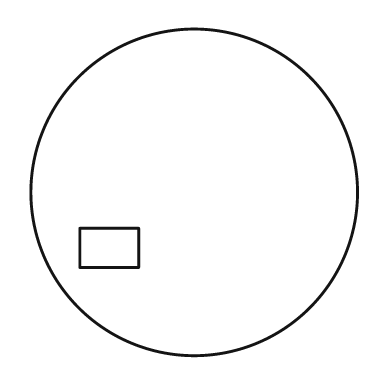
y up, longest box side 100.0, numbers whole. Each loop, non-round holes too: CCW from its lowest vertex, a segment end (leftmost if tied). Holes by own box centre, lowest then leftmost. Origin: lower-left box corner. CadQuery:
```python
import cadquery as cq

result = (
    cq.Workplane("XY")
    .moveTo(50.0, 50.0)
    .circle(50.0)
    .moveTo(15.0, 27.0)
    .lineTo(33.0, 27.0)
    .lineTo(33.0, 39.0)
    .lineTo(15.0, 39.0)
    .close()
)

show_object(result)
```